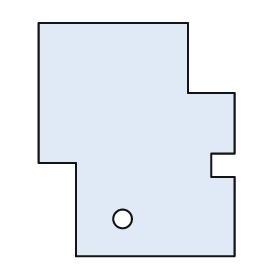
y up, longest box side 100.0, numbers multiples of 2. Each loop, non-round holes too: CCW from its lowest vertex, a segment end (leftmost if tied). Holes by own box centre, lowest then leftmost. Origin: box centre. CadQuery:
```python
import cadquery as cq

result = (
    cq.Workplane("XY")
    .moveTo(-26.0, -50.0)
    .lineTo(42.0, -50.0)
    .lineTo(42.0, -16.0)
    .lineTo(32.0, -16.0)
    .lineTo(32.0, -6.0)
    .lineTo(42.0, -6.0)
    .lineTo(42.0, 20.0)
    .lineTo(22.0, 20.0)
    .lineTo(22.0, 50.0)
    .lineTo(-42.0, 50.0)
    .lineTo(-42.0, -10.0)
    .lineTo(-26.0, -10.0)
    .close()
    .moveTo(-6.0, -34.0)
    .circle(4.0)
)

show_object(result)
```